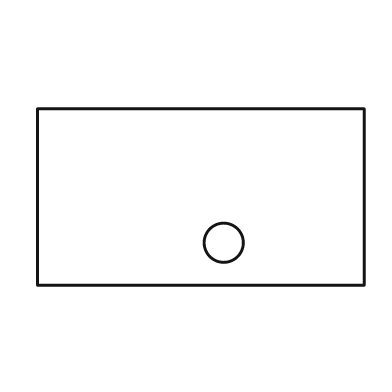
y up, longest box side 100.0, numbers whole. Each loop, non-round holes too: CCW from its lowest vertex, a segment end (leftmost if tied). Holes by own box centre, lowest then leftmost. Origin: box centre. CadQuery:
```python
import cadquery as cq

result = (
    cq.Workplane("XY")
    .moveTo(-50.0, -27.0)
    .lineTo(50.0, -27.0)
    .lineTo(50.0, 27.0)
    .lineTo(-50.0, 27.0)
    .close()
    .moveTo(7.0, -14.0)
    .circle(6.0)
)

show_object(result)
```